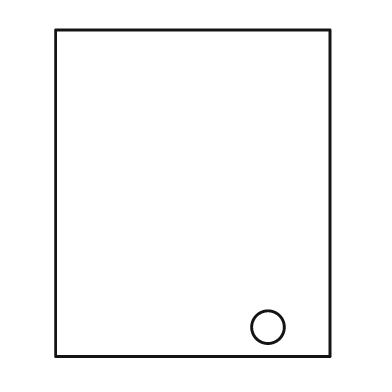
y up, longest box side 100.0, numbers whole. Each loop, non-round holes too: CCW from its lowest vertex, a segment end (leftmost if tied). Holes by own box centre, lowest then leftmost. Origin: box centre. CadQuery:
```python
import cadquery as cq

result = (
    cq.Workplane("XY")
    .moveTo(-42.0, -50.0)
    .lineTo(42.0, -50.0)
    .lineTo(42.0, 50.0)
    .lineTo(-42.0, 50.0)
    .close()
    .moveTo(23.0, -41.0)
    .circle(5.0)
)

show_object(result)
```